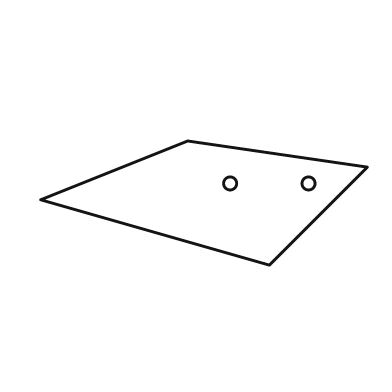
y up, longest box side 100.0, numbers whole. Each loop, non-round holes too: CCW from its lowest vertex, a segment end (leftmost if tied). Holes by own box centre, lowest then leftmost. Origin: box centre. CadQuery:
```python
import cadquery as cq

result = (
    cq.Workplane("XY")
    .moveTo(20.0, -19.0)
    .lineTo(50.0, 11.0)
    .lineTo(-5.0, 19.0)
    .lineTo(-50.0, 1.0)
    .close()
    .moveTo(8.0, 6.0)
    .circle(2.0)
    .moveTo(32.0, 6.0)
    .circle(2.0)
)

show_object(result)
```